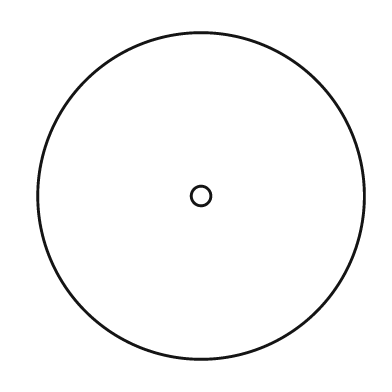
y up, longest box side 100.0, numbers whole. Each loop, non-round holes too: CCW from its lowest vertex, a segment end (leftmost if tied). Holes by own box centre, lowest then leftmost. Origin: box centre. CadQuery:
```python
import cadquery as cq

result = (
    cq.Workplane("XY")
    .moveTo(0.0, 0.0)
    .circle(50.0)
    .moveTo(0.0, 0.0)
    .circle(3.0)
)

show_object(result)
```